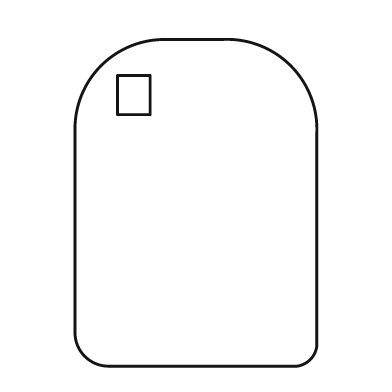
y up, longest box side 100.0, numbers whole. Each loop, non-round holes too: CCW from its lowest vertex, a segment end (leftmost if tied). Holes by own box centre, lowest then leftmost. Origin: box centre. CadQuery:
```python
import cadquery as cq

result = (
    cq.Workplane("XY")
    .moveTo(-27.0, -50.0)
    .lineTo(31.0, -50.0)
    .threePointArc((35.0, -48.0), (37.0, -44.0))
    .lineTo(37.0, 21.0)
    .threePointArc((29.0, 42.0), (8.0, 50.0))
    .lineTo(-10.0, 50.0)
    .threePointArc((-29.0, 42.0), (-37.0, 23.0))
    .lineTo(-37.0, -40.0)
    .threePointArc((-34.0, -47.0), (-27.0, -50.0))
    .close()
    .moveTo(-24.0, 27.0)
    .lineTo(-14.0, 27.0)
    .lineTo(-14.0, 39.0)
    .lineTo(-24.0, 39.0)
    .close()
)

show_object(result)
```